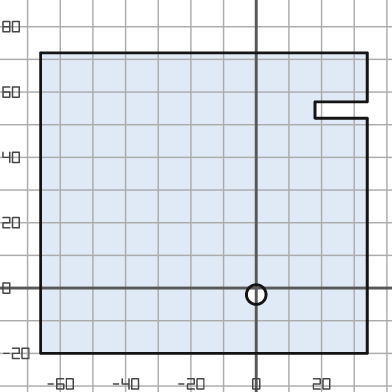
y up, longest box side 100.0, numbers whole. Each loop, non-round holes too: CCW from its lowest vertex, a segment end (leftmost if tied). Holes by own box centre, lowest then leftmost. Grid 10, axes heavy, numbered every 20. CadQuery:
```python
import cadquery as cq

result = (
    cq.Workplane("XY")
    .moveTo(-66.0, -20.0)
    .lineTo(34.0, -20.0)
    .lineTo(34.0, 52.0)
    .lineTo(18.0, 52.0)
    .lineTo(18.0, 57.0)
    .lineTo(34.0, 57.0)
    .lineTo(34.0, 72.0)
    .lineTo(-66.0, 72.0)
    .close()
    .moveTo(0.0, -2.0)
    .circle(3.0)
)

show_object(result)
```